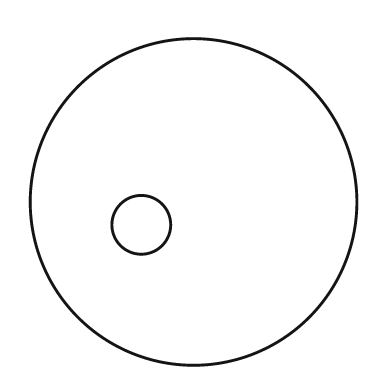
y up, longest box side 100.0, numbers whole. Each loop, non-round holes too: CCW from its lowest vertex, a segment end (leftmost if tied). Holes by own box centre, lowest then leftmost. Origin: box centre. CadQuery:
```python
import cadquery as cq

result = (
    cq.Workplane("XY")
    .moveTo(0.0, 0.0)
    .circle(50.0)
    .moveTo(-16.0, -7.0)
    .circle(9.0)
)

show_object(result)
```